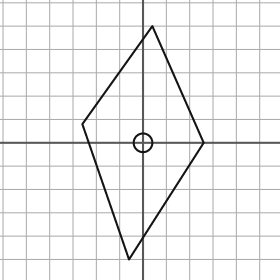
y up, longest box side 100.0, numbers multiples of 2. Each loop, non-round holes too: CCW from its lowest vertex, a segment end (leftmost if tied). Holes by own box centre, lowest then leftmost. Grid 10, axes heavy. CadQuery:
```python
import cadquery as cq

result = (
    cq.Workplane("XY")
    .moveTo(-6.0, -50.0)
    .lineTo(26.0, 0.0)
    .lineTo(4.0, 50.0)
    .lineTo(-26.0, 8.0)
    .close()
    .moveTo(0.0, 0.0)
    .circle(4.0)
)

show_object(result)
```